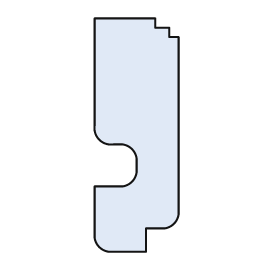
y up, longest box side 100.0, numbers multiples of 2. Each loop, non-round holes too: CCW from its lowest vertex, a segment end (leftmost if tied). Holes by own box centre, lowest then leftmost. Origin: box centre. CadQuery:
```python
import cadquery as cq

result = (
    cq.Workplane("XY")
    .moveTo(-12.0, -50.0)
    .lineTo(4.0, -50.0)
    .lineTo(4.0, -40.0)
    .lineTo(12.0, -40.0)
    .threePointArc((16.0, -38.0), (18.0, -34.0))
    .lineTo(18.0, 42.0)
    .lineTo(14.0, 42.0)
    .lineTo(14.0, 46.0)
    .lineTo(8.0, 46.0)
    .lineTo(8.0, 50.0)
    .lineTo(-18.0, 50.0)
    .lineTo(-18.0, 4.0)
    .threePointArc((-16.0, -2.0), (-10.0, -4.0))
    .lineTo(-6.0, -4.0)
    .threePointArc((-2.0, -6.0), (0.0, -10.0))
    .lineTo(0.0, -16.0)
    .threePointArc((-2.0, -20.0), (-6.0, -22.0))
    .lineTo(-18.0, -22.0)
    .lineTo(-18.0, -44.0)
    .threePointArc((-16.0, -48.0), (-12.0, -50.0))
    .close()
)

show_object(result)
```